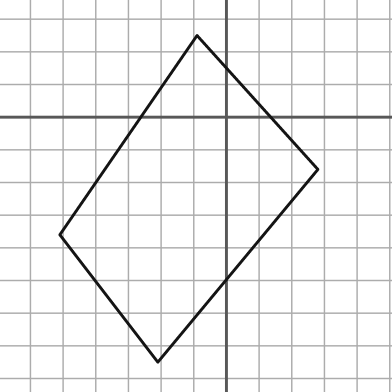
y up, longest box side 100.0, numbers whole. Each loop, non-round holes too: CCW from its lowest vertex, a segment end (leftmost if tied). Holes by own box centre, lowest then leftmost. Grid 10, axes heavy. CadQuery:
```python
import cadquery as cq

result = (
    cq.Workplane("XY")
    .moveTo(-21.0, -75.0)
    .lineTo(28.0, -16.0)
    .lineTo(-9.0, 25.0)
    .lineTo(-51.0, -36.0)
    .close()
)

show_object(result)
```